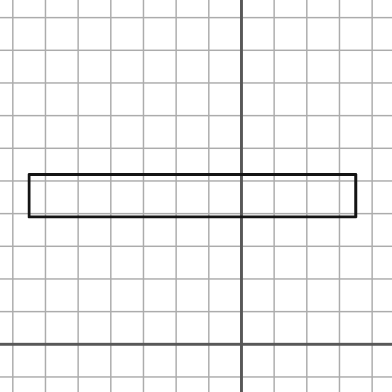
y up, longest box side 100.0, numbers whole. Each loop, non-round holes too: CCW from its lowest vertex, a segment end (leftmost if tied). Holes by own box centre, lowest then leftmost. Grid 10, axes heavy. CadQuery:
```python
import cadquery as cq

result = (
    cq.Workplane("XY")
    .moveTo(-65.0, 39.0)
    .lineTo(35.0, 39.0)
    .lineTo(35.0, 52.0)
    .lineTo(-65.0, 52.0)
    .close()
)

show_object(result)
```